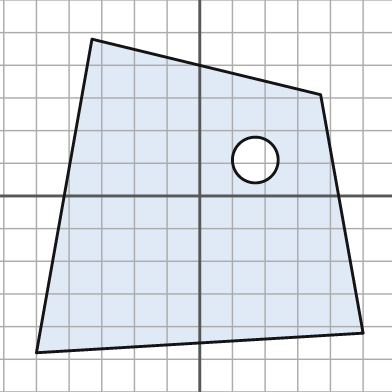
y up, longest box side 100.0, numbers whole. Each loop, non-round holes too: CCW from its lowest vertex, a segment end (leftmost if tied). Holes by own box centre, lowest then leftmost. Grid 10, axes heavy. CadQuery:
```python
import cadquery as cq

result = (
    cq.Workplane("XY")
    .moveTo(-50.0, -48.0)
    .lineTo(50.0, -42.0)
    .lineTo(37.0, 31.0)
    .lineTo(-33.0, 48.0)
    .close()
    .moveTo(17.0, 11.0)
    .circle(7.0)
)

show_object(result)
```